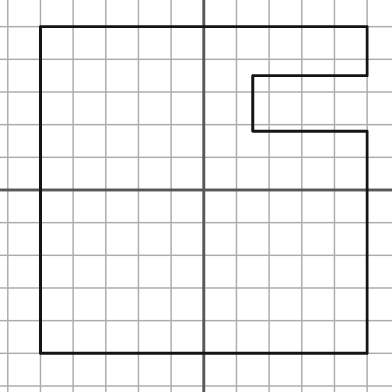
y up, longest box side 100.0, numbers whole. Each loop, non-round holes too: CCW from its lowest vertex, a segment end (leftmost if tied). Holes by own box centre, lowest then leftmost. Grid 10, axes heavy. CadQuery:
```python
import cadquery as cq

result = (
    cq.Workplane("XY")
    .moveTo(-50.0, -50.0)
    .lineTo(50.0, -50.0)
    .lineTo(50.0, 18.0)
    .lineTo(15.0, 18.0)
    .lineTo(15.0, 35.0)
    .lineTo(50.0, 35.0)
    .lineTo(50.0, 50.0)
    .lineTo(-50.0, 50.0)
    .close()
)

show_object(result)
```